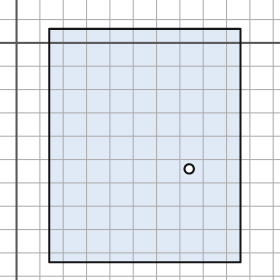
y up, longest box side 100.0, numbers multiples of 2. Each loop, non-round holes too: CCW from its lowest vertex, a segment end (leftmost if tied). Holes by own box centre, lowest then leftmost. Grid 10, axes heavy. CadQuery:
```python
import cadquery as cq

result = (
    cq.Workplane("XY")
    .moveTo(14.0, -94.0)
    .lineTo(96.0, -94.0)
    .lineTo(96.0, 6.0)
    .lineTo(14.0, 6.0)
    .close()
    .moveTo(74.0, -54.0)
    .circle(2.0)
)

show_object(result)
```